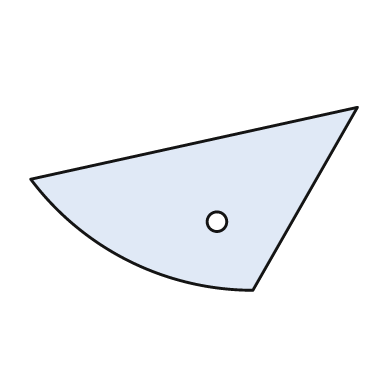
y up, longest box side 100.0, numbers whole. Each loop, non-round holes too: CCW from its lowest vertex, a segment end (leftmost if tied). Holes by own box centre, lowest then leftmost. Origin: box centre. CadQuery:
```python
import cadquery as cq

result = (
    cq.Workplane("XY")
    .moveTo(18.0, -28.0)
    .lineTo(50.0, 28.0)
    .lineTo(-50.0, 6.0)
    .threePointArc((-20.0, -19.0), (18.0, -28.0))
    .close()
    .moveTo(7.0, -7.0)
    .circle(3.0)
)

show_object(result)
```